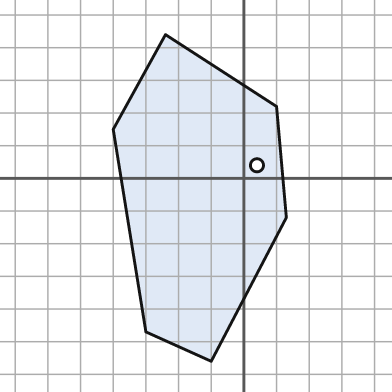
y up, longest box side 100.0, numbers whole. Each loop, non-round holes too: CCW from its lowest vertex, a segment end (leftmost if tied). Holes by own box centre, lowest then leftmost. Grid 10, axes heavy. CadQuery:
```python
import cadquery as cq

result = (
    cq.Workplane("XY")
    .moveTo(-10.0, -56.0)
    .lineTo(13.0, -12.0)
    .lineTo(10.0, 22.0)
    .lineTo(-24.0, 44.0)
    .lineTo(-40.0, 15.0)
    .lineTo(-30.0, -47.0)
    .close()
    .moveTo(4.0, 4.0)
    .circle(2.0)
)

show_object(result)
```